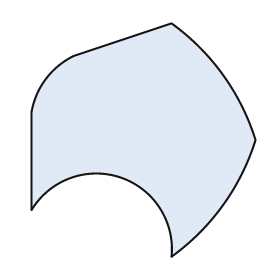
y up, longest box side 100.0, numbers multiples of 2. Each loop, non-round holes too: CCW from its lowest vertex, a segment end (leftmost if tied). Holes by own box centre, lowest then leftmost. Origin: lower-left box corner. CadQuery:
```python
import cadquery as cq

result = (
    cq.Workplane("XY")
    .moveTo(60.0, 0.0)
    .threePointArc((82.0, 22.0), (96.0, 50.0))
    .threePointArc((82.0, 78.0), (60.0, 100.0))
    .lineTo(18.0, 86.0)
    .threePointArc((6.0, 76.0), (0.0, 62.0))
    .lineTo(0.0, 20.0)
    .threePointArc((38.0, 34.0), (60.0, 0.0))
    .close()
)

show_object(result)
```